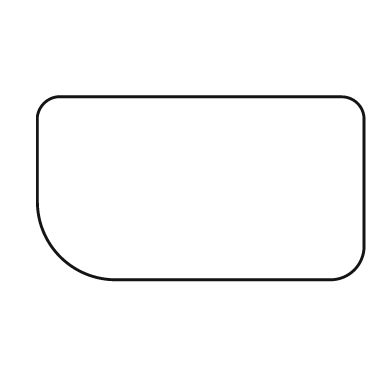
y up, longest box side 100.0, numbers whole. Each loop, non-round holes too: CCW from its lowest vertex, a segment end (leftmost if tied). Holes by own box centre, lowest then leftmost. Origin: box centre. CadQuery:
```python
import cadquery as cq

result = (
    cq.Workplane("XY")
    .moveTo(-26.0, -28.0)
    .lineTo(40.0, -28.0)
    .threePointArc((47.0, -25.0), (50.0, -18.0))
    .lineTo(50.0, 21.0)
    .threePointArc((48.0, 26.0), (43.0, 28.0))
    .lineTo(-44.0, 28.0)
    .threePointArc((-48.0, 26.0), (-50.0, 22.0))
    .lineTo(-50.0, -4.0)
    .threePointArc((-43.0, -21.0), (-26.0, -28.0))
    .close()
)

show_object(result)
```